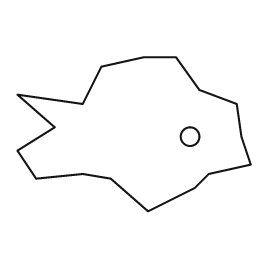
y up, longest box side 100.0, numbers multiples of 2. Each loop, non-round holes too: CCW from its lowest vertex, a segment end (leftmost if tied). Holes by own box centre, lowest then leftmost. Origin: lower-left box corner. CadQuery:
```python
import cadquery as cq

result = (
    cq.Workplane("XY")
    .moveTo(56.0, 0.0)
    .lineTo(76.0, 10.0)
    .lineTo(82.0, 16.0)
    .lineTo(100.0, 20.0)
    .lineTo(96.0, 32.0)
    .lineTo(94.0, 46.0)
    .lineTo(78.0, 52.0)
    .lineTo(68.0, 66.0)
    .lineTo(54.0, 66.0)
    .lineTo(36.0, 62.0)
    .lineTo(28.0, 46.0)
    .lineTo(0.0, 50.0)
    .lineTo(16.0, 36.0)
    .lineTo(0.0, 26.0)
    .lineTo(8.0, 14.0)
    .lineTo(28.0, 16.0)
    .lineTo(40.0, 14.0)
    .close()
    .moveTo(74.0, 32.0)
    .circle(4.0)
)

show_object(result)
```